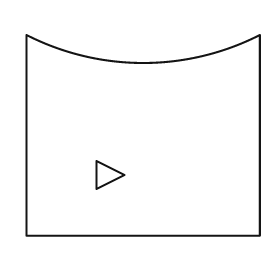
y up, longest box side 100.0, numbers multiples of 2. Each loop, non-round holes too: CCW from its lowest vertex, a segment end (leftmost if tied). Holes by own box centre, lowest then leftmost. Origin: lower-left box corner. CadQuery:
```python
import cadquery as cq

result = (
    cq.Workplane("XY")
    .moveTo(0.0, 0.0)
    .lineTo(100.0, 0.0)
    .lineTo(100.0, 86.0)
    .threePointArc((50.0, 74.0), (0.0, 86.0))
    .close()
    .moveTo(30.0, 20.0)
    .lineTo(42.0, 26.0)
    .lineTo(30.0, 32.0)
    .close()
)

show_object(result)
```